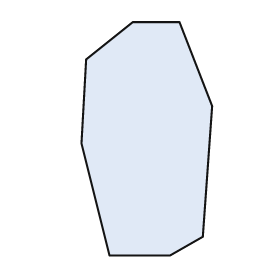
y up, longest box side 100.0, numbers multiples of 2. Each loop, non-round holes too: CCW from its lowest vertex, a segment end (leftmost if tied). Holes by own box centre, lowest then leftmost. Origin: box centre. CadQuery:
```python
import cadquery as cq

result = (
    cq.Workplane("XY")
    .moveTo(-16.0, -50.0)
    .lineTo(10.0, -50.0)
    .lineTo(24.0, -42.0)
    .lineTo(28.0, 14.0)
    .lineTo(14.0, 50.0)
    .lineTo(-6.0, 50.0)
    .lineTo(-26.0, 34.0)
    .lineTo(-28.0, -2.0)
    .close()
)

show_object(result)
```